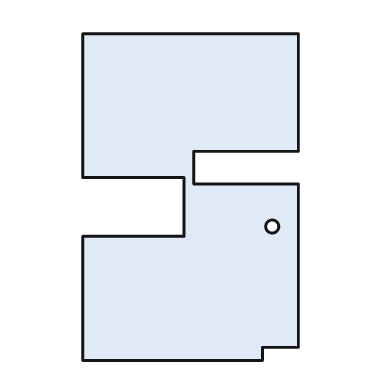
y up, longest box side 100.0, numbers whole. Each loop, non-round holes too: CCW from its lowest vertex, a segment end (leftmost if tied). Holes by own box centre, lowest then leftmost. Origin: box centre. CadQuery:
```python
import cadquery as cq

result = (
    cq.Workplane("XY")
    .moveTo(-33.0, -50.0)
    .lineTo(22.0, -50.0)
    .lineTo(22.0, -46.0)
    .lineTo(33.0, -46.0)
    .lineTo(33.0, 4.0)
    .lineTo(1.0, 4.0)
    .lineTo(1.0, 14.0)
    .lineTo(33.0, 14.0)
    .lineTo(33.0, 50.0)
    .lineTo(-33.0, 50.0)
    .lineTo(-33.0, 6.0)
    .lineTo(-2.0, 6.0)
    .lineTo(-2.0, -12.0)
    .lineTo(-33.0, -12.0)
    .close()
    .moveTo(25.0, -9.0)
    .circle(2.0)
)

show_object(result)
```